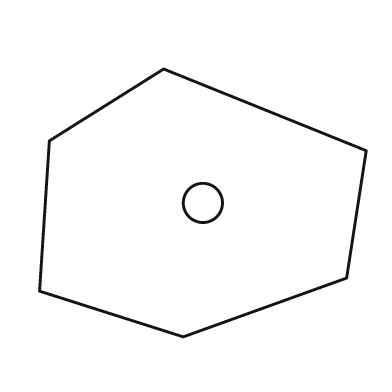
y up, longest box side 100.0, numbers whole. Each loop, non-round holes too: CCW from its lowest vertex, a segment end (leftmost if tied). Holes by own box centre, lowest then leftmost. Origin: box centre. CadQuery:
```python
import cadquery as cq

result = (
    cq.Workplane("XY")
    .moveTo(-6.0, -41.0)
    .lineTo(44.0, -23.0)
    .lineTo(50.0, 16.0)
    .lineTo(-12.0, 41.0)
    .lineTo(-47.0, 19.0)
    .lineTo(-50.0, -27.0)
    .close()
    .moveTo(0.0, 0.0)
    .circle(6.0)
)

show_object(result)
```